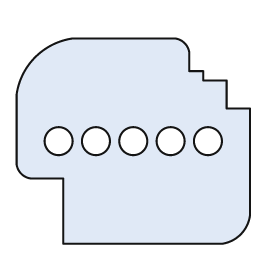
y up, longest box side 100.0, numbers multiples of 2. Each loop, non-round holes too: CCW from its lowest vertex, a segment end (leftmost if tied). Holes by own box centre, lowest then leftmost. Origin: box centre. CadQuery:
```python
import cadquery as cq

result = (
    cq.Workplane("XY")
    .moveTo(-30.0, -44.0)
    .lineTo(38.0, -44.0)
    .threePointArc((46.0, -40.0), (50.0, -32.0))
    .lineTo(50.0, 14.0)
    .lineTo(40.0, 14.0)
    .lineTo(40.0, 26.0)
    .lineTo(30.0, 26.0)
    .lineTo(30.0, 30.0)
    .lineTo(24.0, 30.0)
    .lineTo(24.0, 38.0)
    .threePointArc((22.0, 42.0), (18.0, 44.0))
    .lineTo(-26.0, 44.0)
    .threePointArc((-42.0, 36.0), (-50.0, 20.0))
    .lineTo(-50.0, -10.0)
    .threePointArc((-48.0, -14.0), (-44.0, -16.0))
    .lineTo(-30.0, -16.0)
    .close()
    .moveTo(-32.0, 0.0)
    .circle(6.0)
    .moveTo(-16.0, 0.0)
    .circle(6.0)
    .moveTo(0.0, 0.0)
    .circle(6.0)
    .moveTo(16.0, 0.0)
    .circle(6.0)
    .moveTo(32.0, 0.0)
    .circle(6.0)
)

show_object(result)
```